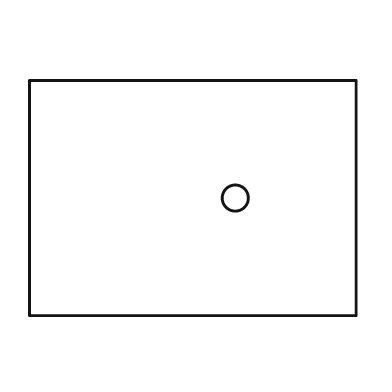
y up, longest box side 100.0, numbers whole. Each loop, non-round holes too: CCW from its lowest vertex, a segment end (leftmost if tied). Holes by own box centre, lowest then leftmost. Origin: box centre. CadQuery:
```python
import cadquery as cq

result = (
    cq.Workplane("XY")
    .moveTo(-50.0, -36.0)
    .lineTo(50.0, -36.0)
    .lineTo(50.0, 36.0)
    .lineTo(-50.0, 36.0)
    .close()
    .moveTo(13.0, 0.0)
    .circle(4.0)
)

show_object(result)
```